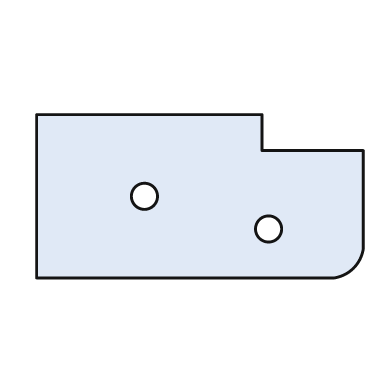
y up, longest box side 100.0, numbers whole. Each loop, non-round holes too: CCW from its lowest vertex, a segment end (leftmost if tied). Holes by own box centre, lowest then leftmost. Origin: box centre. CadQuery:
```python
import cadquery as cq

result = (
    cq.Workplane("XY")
    .moveTo(-50.0, -25.0)
    .lineTo(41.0, -25.0)
    .threePointArc((47.0, -22.0), (50.0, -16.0))
    .lineTo(50.0, 14.0)
    .lineTo(19.0, 14.0)
    .lineTo(19.0, 25.0)
    .lineTo(-50.0, 25.0)
    .close()
    .moveTo(21.0, -10.0)
    .circle(4.0)
    .moveTo(-17.0, 0.0)
    .circle(4.0)
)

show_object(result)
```